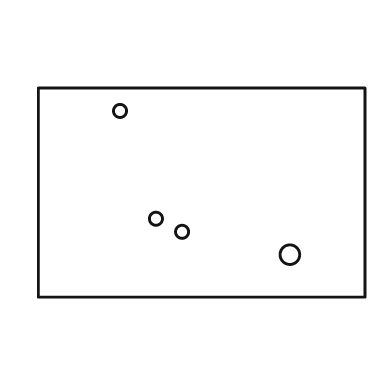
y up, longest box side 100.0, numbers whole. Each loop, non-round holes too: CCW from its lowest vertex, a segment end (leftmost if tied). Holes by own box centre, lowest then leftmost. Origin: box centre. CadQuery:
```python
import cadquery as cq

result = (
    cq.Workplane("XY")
    .moveTo(-50.0, -32.0)
    .lineTo(50.0, -32.0)
    .lineTo(50.0, 32.0)
    .lineTo(-50.0, 32.0)
    .close()
    .moveTo(27.0, -19.0)
    .circle(3.0)
    .moveTo(-6.0, -12.0)
    .circle(2.0)
    .moveTo(-14.0, -8.0)
    .circle(2.0)
    .moveTo(-25.0, 25.0)
    .circle(2.0)
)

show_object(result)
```